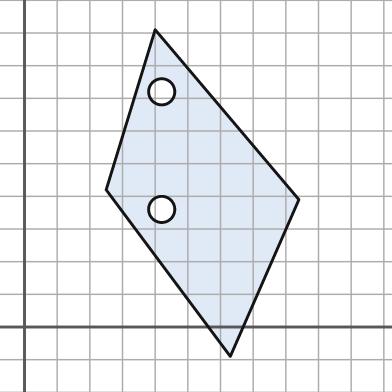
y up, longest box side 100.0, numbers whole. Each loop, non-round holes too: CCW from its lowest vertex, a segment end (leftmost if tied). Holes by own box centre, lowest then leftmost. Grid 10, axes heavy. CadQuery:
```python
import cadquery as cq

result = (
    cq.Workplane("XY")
    .moveTo(63.0, -9.0)
    .lineTo(84.0, 39.0)
    .lineTo(40.0, 91.0)
    .lineTo(25.0, 42.0)
    .close()
    .moveTo(42.0, 36.0)
    .circle(4.0)
    .moveTo(42.0, 72.0)
    .circle(4.0)
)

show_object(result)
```